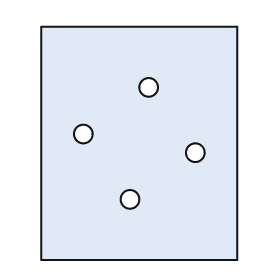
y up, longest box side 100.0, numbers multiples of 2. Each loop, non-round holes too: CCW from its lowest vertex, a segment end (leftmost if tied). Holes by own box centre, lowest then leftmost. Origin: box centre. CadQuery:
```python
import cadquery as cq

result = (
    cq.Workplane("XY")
    .moveTo(-42.0, -50.0)
    .lineTo(42.0, -50.0)
    .lineTo(42.0, 50.0)
    .lineTo(-42.0, 50.0)
    .close()
    .moveTo(-4.0, -24.0)
    .circle(4.0)
    .moveTo(24.0, -4.0)
    .circle(4.0)
    .moveTo(-24.0, 4.0)
    .circle(4.0)
    .moveTo(4.0, 24.0)
    .circle(4.0)
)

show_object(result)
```